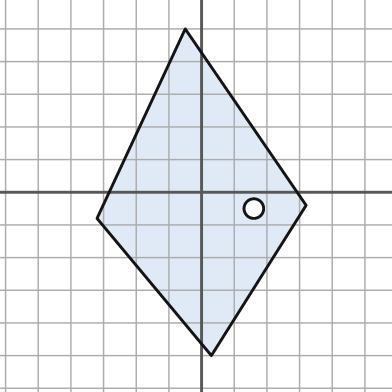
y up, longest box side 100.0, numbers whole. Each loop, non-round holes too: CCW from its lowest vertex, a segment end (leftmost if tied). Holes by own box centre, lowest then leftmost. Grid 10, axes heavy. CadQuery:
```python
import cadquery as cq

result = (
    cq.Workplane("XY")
    .moveTo(3.0, -50.0)
    .lineTo(32.0, -4.0)
    .lineTo(-5.0, 50.0)
    .lineTo(-32.0, -8.0)
    .close()
    .moveTo(16.0, -5.0)
    .circle(3.0)
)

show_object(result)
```